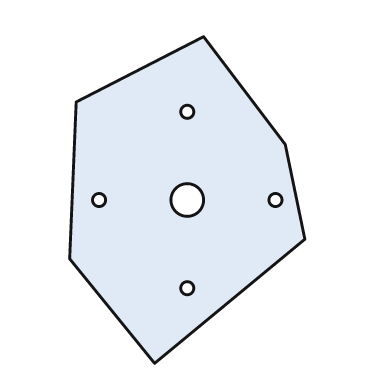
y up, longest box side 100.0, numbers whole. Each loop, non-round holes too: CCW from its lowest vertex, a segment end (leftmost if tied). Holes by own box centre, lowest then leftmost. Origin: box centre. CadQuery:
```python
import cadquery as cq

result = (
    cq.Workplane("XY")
    .moveTo(-10.0, -50.0)
    .lineTo(36.0, -12.0)
    .lineTo(30.0, 17.0)
    .lineTo(5.0, 50.0)
    .lineTo(-34.0, 30.0)
    .lineTo(-36.0, -18.0)
    .close()
    .moveTo(0.0, -27.0)
    .circle(2.0)
    .moveTo(-27.0, 0.0)
    .circle(2.0)
    .moveTo(0.0, 0.0)
    .circle(5.0)
    .moveTo(27.0, 0.0)
    .circle(2.0)
    .moveTo(0.0, 27.0)
    .circle(2.0)
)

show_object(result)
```